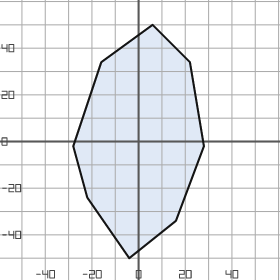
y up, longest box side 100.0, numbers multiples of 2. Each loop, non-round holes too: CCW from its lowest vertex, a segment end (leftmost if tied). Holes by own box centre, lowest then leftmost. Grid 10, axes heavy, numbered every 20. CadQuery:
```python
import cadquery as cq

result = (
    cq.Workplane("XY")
    .moveTo(-4.0, -50.0)
    .lineTo(16.0, -34.0)
    .lineTo(28.0, -2.0)
    .lineTo(22.0, 34.0)
    .lineTo(6.0, 50.0)
    .lineTo(-16.0, 34.0)
    .lineTo(-28.0, -2.0)
    .lineTo(-22.0, -24.0)
    .close()
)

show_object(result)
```